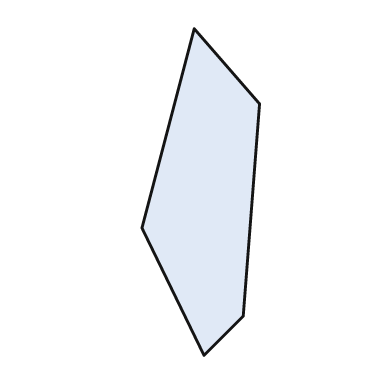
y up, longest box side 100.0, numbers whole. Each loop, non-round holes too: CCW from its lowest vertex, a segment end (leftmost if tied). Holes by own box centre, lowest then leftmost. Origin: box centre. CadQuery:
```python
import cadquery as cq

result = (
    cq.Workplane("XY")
    .moveTo(1.0, -50.0)
    .lineTo(13.0, -38.0)
    .lineTo(18.0, 27.0)
    .lineTo(-2.0, 50.0)
    .lineTo(-18.0, -11.0)
    .close()
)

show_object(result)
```